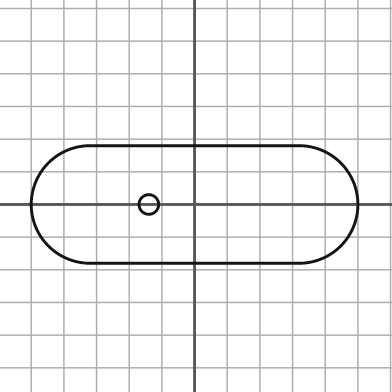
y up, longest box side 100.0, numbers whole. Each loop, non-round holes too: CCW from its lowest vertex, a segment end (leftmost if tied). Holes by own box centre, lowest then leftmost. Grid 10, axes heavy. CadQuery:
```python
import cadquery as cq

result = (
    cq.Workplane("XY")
    .moveTo(-32.0, -18.0)
    .lineTo(32.0, -18.0)
    .threePointArc((50.0, 0.0), (32.0, 18.0))
    .lineTo(-32.0, 18.0)
    .threePointArc((-50.0, 0.0), (-32.0, -18.0))
    .close()
    .moveTo(-14.0, 0.0)
    .circle(3.0)
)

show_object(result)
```